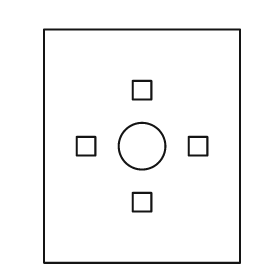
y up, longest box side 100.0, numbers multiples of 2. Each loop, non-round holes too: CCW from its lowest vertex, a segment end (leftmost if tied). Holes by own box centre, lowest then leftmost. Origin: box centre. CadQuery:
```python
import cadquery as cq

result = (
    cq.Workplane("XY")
    .moveTo(-42.0, -50.0)
    .lineTo(42.0, -50.0)
    .lineTo(42.0, 50.0)
    .lineTo(-42.0, 50.0)
    .close()
    .moveTo(-4.0, -28.0)
    .lineTo(4.0, -28.0)
    .lineTo(4.0, -20.0)
    .lineTo(-4.0, -20.0)
    .close()
    .moveTo(-28.0, -4.0)
    .lineTo(-20.0, -4.0)
    .lineTo(-20.0, 4.0)
    .lineTo(-28.0, 4.0)
    .close()
    .moveTo(0.0, 0.0)
    .circle(10.0)
    .moveTo(20.0, -4.0)
    .lineTo(28.0, -4.0)
    .lineTo(28.0, 4.0)
    .lineTo(20.0, 4.0)
    .close()
    .moveTo(-4.0, 20.0)
    .lineTo(4.0, 20.0)
    .lineTo(4.0, 28.0)
    .lineTo(-4.0, 28.0)
    .close()
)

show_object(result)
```